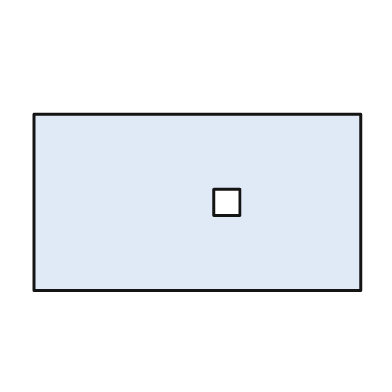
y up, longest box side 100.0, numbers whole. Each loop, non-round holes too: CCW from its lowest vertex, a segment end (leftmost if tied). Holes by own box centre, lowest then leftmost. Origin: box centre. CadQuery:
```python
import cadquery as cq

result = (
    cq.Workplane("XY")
    .moveTo(-50.0, -27.0)
    .lineTo(50.0, -27.0)
    .lineTo(50.0, 27.0)
    .lineTo(-50.0, 27.0)
    .close()
    .moveTo(5.0, -4.0)
    .lineTo(13.0, -4.0)
    .lineTo(13.0, 4.0)
    .lineTo(5.0, 4.0)
    .close()
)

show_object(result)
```